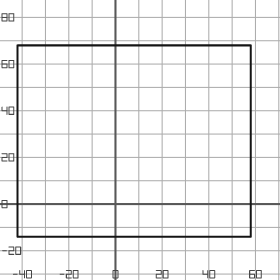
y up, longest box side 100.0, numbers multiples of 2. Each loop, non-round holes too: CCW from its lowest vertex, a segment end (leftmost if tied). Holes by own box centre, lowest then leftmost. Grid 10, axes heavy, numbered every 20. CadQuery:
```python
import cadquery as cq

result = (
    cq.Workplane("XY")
    .moveTo(-42.0, -14.0)
    .lineTo(58.0, -14.0)
    .lineTo(58.0, 68.0)
    .lineTo(-42.0, 68.0)
    .close()
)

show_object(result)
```